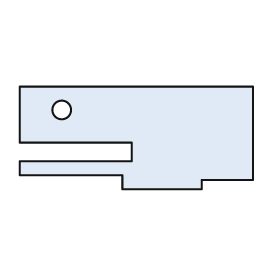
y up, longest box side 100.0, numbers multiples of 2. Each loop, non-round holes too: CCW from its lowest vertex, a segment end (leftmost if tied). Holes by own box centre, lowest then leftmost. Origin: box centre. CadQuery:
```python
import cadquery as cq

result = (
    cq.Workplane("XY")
    .moveTo(-6.0, -22.0)
    .lineTo(28.0, -22.0)
    .lineTo(28.0, -18.0)
    .lineTo(50.0, -18.0)
    .lineTo(50.0, 22.0)
    .lineTo(-50.0, 22.0)
    .lineTo(-50.0, -2.0)
    .lineTo(-2.0, -2.0)
    .lineTo(-2.0, -10.0)
    .lineTo(-50.0, -10.0)
    .lineTo(-50.0, -16.0)
    .lineTo(-6.0, -16.0)
    .close()
    .moveTo(-32.0, 12.0)
    .circle(4.0)
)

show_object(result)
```